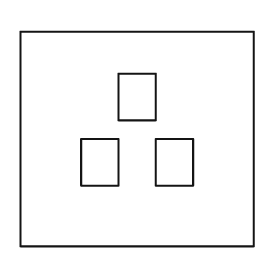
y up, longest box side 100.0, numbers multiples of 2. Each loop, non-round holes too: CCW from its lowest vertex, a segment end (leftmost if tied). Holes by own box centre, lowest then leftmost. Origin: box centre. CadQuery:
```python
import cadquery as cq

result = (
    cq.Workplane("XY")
    .moveTo(-50.0, -46.0)
    .lineTo(50.0, -46.0)
    .lineTo(50.0, 46.0)
    .lineTo(-50.0, 46.0)
    .close()
    .moveTo(-24.0, -20.0)
    .lineTo(-8.0, -20.0)
    .lineTo(-8.0, 0.0)
    .lineTo(-24.0, 0.0)
    .close()
    .moveTo(8.0, -20.0)
    .lineTo(24.0, -20.0)
    .lineTo(24.0, 0.0)
    .lineTo(8.0, 0.0)
    .close()
    .moveTo(-8.0, 8.0)
    .lineTo(8.0, 8.0)
    .lineTo(8.0, 28.0)
    .lineTo(-8.0, 28.0)
    .close()
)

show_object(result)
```